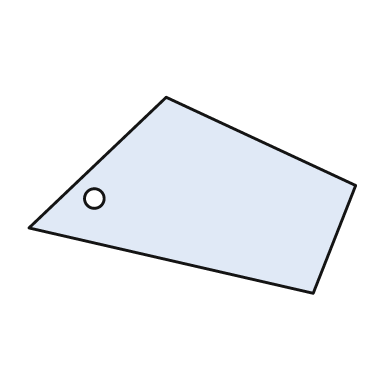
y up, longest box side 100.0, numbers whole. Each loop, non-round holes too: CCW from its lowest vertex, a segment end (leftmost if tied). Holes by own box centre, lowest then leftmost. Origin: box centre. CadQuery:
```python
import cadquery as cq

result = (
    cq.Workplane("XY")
    .moveTo(37.0, -30.0)
    .lineTo(50.0, 3.0)
    .lineTo(-8.0, 30.0)
    .lineTo(-50.0, -10.0)
    .close()
    .moveTo(-30.0, -1.0)
    .circle(3.0)
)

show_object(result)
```